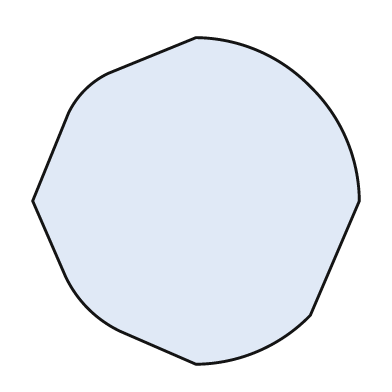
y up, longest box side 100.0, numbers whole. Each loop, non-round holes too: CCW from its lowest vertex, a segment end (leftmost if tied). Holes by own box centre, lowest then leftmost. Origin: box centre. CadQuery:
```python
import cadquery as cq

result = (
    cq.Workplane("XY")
    .moveTo(0.0, -50.0)
    .threePointArc((19.0, -46.0), (35.0, -35.0))
    .lineTo(50.0, 0.0)
    .threePointArc((46.0, 19.0), (35.0, 35.0))
    .threePointArc((19.0, 46.0), (0.0, 50.0))
    .lineTo(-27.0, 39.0)
    .threePointArc((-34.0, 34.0), (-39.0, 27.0))
    .lineTo(-50.0, 0.0)
    .lineTo(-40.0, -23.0)
    .threePointArc((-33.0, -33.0), (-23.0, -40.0))
    .close()
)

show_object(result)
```